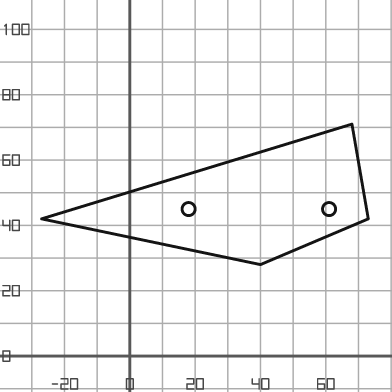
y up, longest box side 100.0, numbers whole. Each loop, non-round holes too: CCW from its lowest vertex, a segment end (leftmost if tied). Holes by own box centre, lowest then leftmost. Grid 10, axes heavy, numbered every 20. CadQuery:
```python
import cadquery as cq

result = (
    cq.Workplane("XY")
    .moveTo(40.0, 28.0)
    .lineTo(73.0, 42.0)
    .lineTo(68.0, 71.0)
    .lineTo(-27.0, 42.0)
    .close()
    .moveTo(18.0, 45.0)
    .circle(2.0)
    .moveTo(61.0, 45.0)
    .circle(2.0)
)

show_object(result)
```